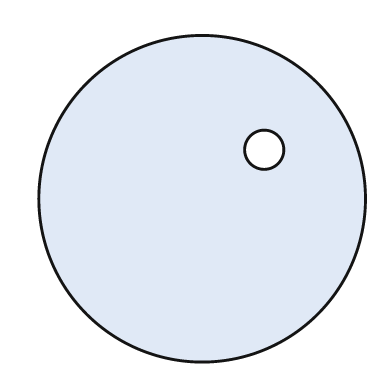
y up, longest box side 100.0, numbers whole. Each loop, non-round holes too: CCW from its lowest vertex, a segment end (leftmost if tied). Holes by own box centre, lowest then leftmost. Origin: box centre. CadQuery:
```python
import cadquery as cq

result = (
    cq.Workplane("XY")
    .moveTo(0.0, 0.0)
    .circle(50.0)
    .moveTo(19.0, 15.0)
    .circle(6.0)
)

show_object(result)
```